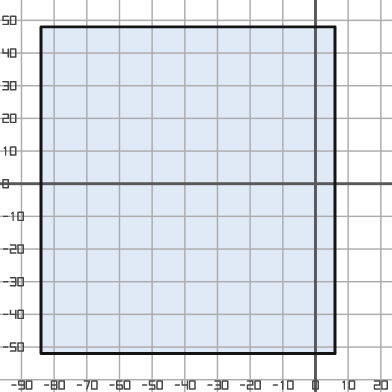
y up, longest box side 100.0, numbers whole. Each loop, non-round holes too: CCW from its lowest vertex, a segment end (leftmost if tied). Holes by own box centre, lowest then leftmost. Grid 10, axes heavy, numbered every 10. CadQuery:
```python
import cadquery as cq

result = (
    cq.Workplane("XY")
    .moveTo(-84.0, -52.0)
    .lineTo(6.0, -52.0)
    .lineTo(6.0, 48.0)
    .lineTo(-84.0, 48.0)
    .close()
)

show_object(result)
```